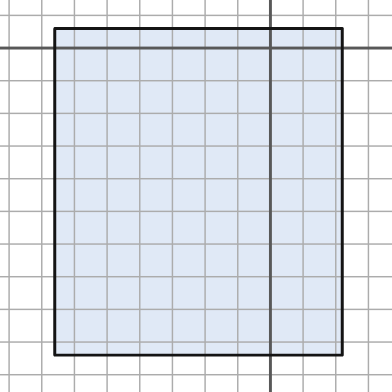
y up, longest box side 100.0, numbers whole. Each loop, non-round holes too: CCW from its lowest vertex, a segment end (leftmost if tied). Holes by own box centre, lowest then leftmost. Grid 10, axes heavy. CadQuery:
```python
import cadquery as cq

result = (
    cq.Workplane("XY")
    .moveTo(-66.0, -94.0)
    .lineTo(22.0, -94.0)
    .lineTo(22.0, 6.0)
    .lineTo(-66.0, 6.0)
    .close()
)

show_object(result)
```